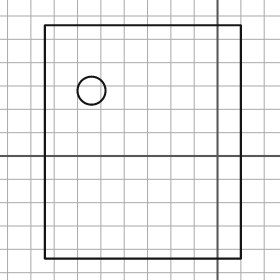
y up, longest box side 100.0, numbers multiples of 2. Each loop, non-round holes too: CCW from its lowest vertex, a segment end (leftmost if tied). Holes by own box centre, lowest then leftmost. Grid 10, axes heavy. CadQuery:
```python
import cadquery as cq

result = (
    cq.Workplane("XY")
    .moveTo(-74.0, -44.0)
    .lineTo(10.0, -44.0)
    .lineTo(10.0, 56.0)
    .lineTo(-74.0, 56.0)
    .close()
    .moveTo(-54.0, 28.0)
    .circle(6.0)
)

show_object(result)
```